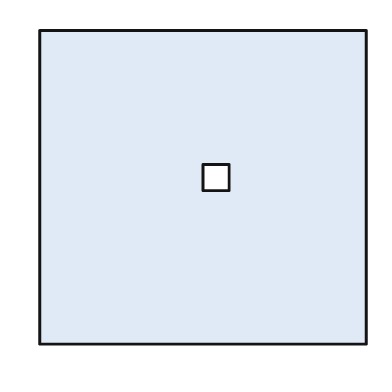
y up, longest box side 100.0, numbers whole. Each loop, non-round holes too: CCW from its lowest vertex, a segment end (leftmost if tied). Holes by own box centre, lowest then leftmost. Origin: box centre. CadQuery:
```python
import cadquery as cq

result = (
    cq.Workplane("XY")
    .moveTo(-50.0, -48.0)
    .lineTo(50.0, -48.0)
    .lineTo(50.0, 48.0)
    .lineTo(-50.0, 48.0)
    .close()
    .moveTo(0.0, -1.0)
    .lineTo(8.0, -1.0)
    .lineTo(8.0, 7.0)
    .lineTo(0.0, 7.0)
    .close()
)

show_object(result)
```